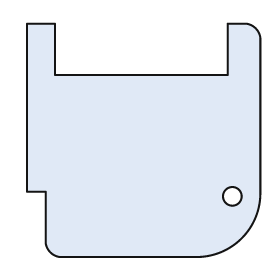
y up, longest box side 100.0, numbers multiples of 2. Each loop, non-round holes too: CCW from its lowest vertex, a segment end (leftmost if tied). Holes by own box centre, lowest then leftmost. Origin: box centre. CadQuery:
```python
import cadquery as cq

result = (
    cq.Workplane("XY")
    .moveTo(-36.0, -50.0)
    .lineTo(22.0, -50.0)
    .threePointArc((42.0, -42.0), (50.0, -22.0))
    .lineTo(50.0, 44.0)
    .threePointArc((48.0, 48.0), (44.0, 50.0))
    .lineTo(36.0, 50.0)
    .lineTo(36.0, 28.0)
    .lineTo(-38.0, 28.0)
    .lineTo(-38.0, 50.0)
    .lineTo(-50.0, 50.0)
    .lineTo(-50.0, -22.0)
    .lineTo(-42.0, -22.0)
    .lineTo(-42.0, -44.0)
    .threePointArc((-40.0, -48.0), (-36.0, -50.0))
    .close()
    .moveTo(38.0, -24.0)
    .circle(4.0)
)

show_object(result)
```